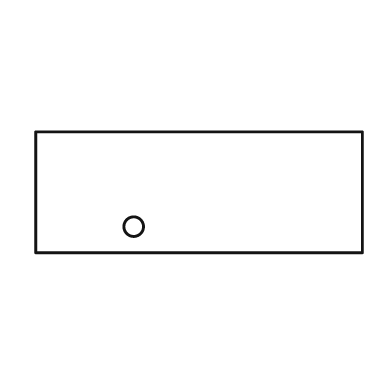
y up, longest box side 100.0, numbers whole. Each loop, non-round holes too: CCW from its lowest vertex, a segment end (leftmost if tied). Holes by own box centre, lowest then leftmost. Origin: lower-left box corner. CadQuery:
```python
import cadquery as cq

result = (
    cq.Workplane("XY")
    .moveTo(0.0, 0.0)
    .lineTo(100.0, 0.0)
    .lineTo(100.0, 37.0)
    .lineTo(0.0, 37.0)
    .close()
    .moveTo(30.0, 8.0)
    .circle(3.0)
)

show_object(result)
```